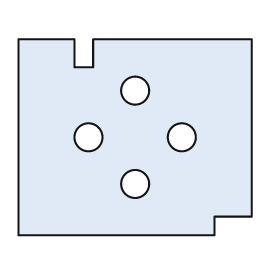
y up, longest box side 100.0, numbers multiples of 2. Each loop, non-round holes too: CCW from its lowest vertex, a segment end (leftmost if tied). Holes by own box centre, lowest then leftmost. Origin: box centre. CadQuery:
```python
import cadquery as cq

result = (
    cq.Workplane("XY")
    .moveTo(-50.0, -42.0)
    .lineTo(34.0, -42.0)
    .lineTo(34.0, -34.0)
    .lineTo(50.0, -34.0)
    .lineTo(50.0, 42.0)
    .lineTo(-18.0, 42.0)
    .lineTo(-18.0, 30.0)
    .lineTo(-26.0, 30.0)
    .lineTo(-26.0, 42.0)
    .lineTo(-50.0, 42.0)
    .close()
    .moveTo(0.0, -20.0)
    .circle(6.0)
    .moveTo(-20.0, 0.0)
    .circle(6.0)
    .moveTo(20.0, 0.0)
    .circle(6.0)
    .moveTo(0.0, 20.0)
    .circle(6.0)
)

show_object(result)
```